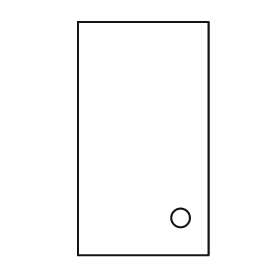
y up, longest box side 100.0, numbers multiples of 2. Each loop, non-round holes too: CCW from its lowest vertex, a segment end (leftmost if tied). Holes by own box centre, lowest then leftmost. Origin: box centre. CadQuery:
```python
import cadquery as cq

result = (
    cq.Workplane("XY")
    .moveTo(-28.0, -50.0)
    .lineTo(28.0, -50.0)
    .lineTo(28.0, 50.0)
    .lineTo(-28.0, 50.0)
    .close()
    .moveTo(16.0, -34.0)
    .circle(4.0)
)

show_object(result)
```